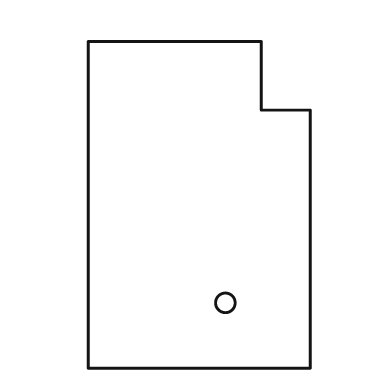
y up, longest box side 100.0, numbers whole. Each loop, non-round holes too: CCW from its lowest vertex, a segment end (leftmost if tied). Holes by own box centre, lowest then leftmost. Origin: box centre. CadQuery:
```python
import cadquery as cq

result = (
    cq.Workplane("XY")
    .moveTo(-34.0, -50.0)
    .lineTo(34.0, -50.0)
    .lineTo(34.0, 29.0)
    .lineTo(19.0, 29.0)
    .lineTo(19.0, 50.0)
    .lineTo(-34.0, 50.0)
    .close()
    .moveTo(8.0, -30.0)
    .circle(3.0)
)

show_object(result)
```